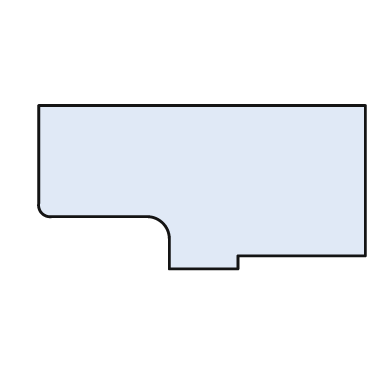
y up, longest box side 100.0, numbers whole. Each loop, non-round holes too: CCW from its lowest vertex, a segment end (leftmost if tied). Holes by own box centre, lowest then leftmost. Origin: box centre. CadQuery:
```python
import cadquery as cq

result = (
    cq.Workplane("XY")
    .moveTo(-10.0, -25.0)
    .lineTo(11.0, -25.0)
    .lineTo(11.0, -21.0)
    .lineTo(50.0, -21.0)
    .lineTo(50.0, 25.0)
    .lineTo(-50.0, 25.0)
    .lineTo(-50.0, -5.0)
    .threePointArc((-49.0, -8.0), (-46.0, -9.0))
    .lineTo(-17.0, -9.0)
    .threePointArc((-12.0, -11.0), (-10.0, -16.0))
    .close()
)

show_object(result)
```